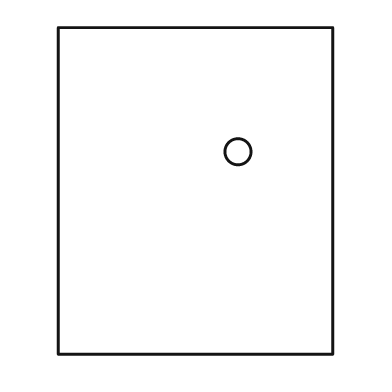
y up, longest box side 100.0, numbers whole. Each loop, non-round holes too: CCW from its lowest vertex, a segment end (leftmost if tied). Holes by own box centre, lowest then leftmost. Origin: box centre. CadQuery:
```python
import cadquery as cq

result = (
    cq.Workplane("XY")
    .moveTo(-42.0, -50.0)
    .lineTo(42.0, -50.0)
    .lineTo(42.0, 50.0)
    .lineTo(-42.0, 50.0)
    .close()
    .moveTo(13.0, 12.0)
    .circle(4.0)
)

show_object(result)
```